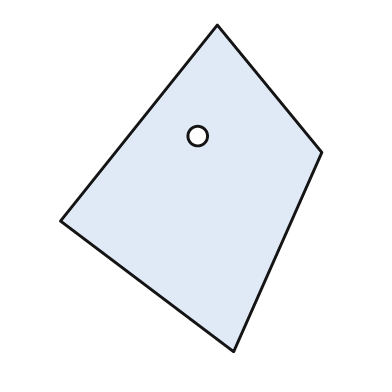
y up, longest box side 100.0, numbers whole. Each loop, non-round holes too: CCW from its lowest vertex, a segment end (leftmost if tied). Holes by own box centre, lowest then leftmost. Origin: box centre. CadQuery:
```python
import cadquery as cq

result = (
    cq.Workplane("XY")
    .moveTo(13.0, -50.0)
    .lineTo(40.0, 11.0)
    .lineTo(8.0, 50.0)
    .lineTo(-40.0, -10.0)
    .close()
    .moveTo(2.0, 16.0)
    .circle(3.0)
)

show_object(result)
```